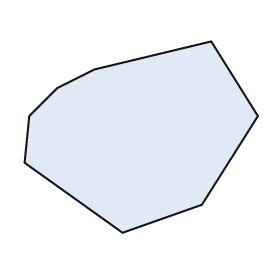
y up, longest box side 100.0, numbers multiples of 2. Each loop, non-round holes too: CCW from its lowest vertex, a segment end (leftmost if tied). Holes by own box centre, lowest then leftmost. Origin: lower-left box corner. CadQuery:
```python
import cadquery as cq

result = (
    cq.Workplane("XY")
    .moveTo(42.0, 0.0)
    .lineTo(76.0, 12.0)
    .lineTo(100.0, 50.0)
    .lineTo(80.0, 82.0)
    .lineTo(30.0, 70.0)
    .lineTo(14.0, 62.0)
    .lineTo(2.0, 50.0)
    .lineTo(0.0, 30.0)
    .close()
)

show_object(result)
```